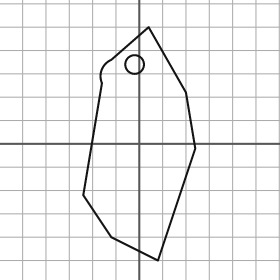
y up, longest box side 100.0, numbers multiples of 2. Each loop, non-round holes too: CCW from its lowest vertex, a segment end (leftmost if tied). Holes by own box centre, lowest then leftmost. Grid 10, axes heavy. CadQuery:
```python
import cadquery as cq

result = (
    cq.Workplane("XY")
    .moveTo(8.0, -50.0)
    .lineTo(24.0, -2.0)
    .lineTo(20.0, 22.0)
    .lineTo(4.0, 50.0)
    .lineTo(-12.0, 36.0)
    .threePointArc((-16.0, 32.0), (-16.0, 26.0))
    .lineTo(-24.0, -22.0)
    .lineTo(-12.0, -40.0)
    .close()
    .moveTo(-2.0, 34.0)
    .circle(4.0)
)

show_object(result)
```